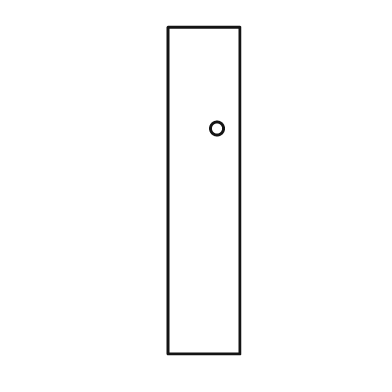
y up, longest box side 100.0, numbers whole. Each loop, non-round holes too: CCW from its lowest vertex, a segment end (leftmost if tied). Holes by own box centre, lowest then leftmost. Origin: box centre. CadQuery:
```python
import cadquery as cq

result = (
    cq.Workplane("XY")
    .moveTo(-11.0, -50.0)
    .lineTo(11.0, -50.0)
    .lineTo(11.0, 50.0)
    .lineTo(-11.0, 50.0)
    .close()
    .moveTo(4.0, 19.0)
    .circle(2.0)
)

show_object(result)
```